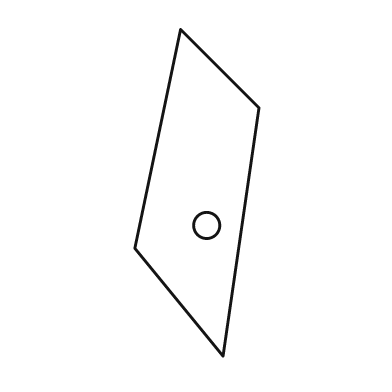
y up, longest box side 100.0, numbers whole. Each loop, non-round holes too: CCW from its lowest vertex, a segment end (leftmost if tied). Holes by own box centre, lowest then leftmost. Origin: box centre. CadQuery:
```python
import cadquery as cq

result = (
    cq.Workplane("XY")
    .moveTo(8.0, -50.0)
    .lineTo(19.0, 26.0)
    .lineTo(-5.0, 50.0)
    .lineTo(-19.0, -17.0)
    .close()
    .moveTo(3.0, -10.0)
    .circle(4.0)
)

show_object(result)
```